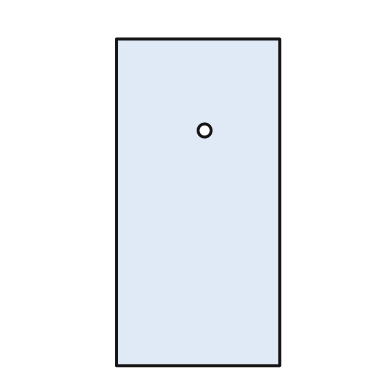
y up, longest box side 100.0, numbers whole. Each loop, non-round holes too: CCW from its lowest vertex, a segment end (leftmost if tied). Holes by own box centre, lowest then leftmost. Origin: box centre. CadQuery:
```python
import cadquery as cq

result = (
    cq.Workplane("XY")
    .moveTo(-25.0, -50.0)
    .lineTo(25.0, -50.0)
    .lineTo(25.0, 50.0)
    .lineTo(-25.0, 50.0)
    .close()
    .moveTo(2.0, 22.0)
    .circle(2.0)
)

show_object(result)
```